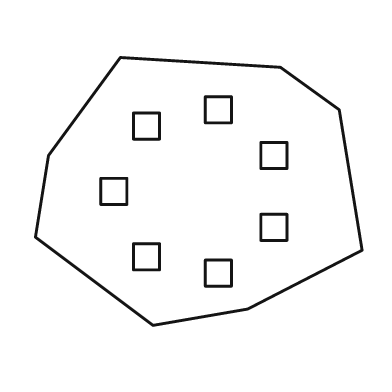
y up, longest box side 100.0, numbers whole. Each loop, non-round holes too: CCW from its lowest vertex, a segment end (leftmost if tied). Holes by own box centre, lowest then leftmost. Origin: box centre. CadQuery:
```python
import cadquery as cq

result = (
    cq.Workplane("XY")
    .moveTo(-14.0, -41.0)
    .lineTo(15.0, -36.0)
    .lineTo(50.0, -18.0)
    .lineTo(43.0, 25.0)
    .lineTo(25.0, 38.0)
    .lineTo(-24.0, 41.0)
    .lineTo(-46.0, 11.0)
    .lineTo(-50.0, -14.0)
    .close()
    .moveTo(2.0, -29.0)
    .lineTo(10.0, -29.0)
    .lineTo(10.0, -21.0)
    .lineTo(2.0, -21.0)
    .close()
    .moveTo(-20.0, -24.0)
    .lineTo(-12.0, -24.0)
    .lineTo(-12.0, -16.0)
    .lineTo(-20.0, -16.0)
    .close()
    .moveTo(19.0, -15.0)
    .lineTo(27.0, -15.0)
    .lineTo(27.0, -7.0)
    .lineTo(19.0, -7.0)
    .close()
    .moveTo(-30.0, -4.0)
    .lineTo(-22.0, -4.0)
    .lineTo(-22.0, 4.0)
    .lineTo(-30.0, 4.0)
    .close()
    .moveTo(19.0, 7.0)
    .lineTo(27.0, 7.0)
    .lineTo(27.0, 15.0)
    .lineTo(19.0, 15.0)
    .close()
    .moveTo(-20.0, 16.0)
    .lineTo(-12.0, 16.0)
    .lineTo(-12.0, 24.0)
    .lineTo(-20.0, 24.0)
    .close()
    .moveTo(2.0, 21.0)
    .lineTo(10.0, 21.0)
    .lineTo(10.0, 29.0)
    .lineTo(2.0, 29.0)
    .close()
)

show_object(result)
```